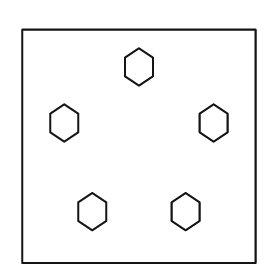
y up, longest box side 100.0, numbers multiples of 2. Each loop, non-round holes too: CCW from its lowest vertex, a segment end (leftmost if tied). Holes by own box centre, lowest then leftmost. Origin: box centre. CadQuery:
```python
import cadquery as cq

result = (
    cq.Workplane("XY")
    .moveTo(-50.0, -50.0)
    .lineTo(50.0, -50.0)
    .lineTo(50.0, 50.0)
    .lineTo(-50.0, 50.0)
    .close()
    .moveTo(-20.0, -36.0)
    .lineTo(-14.0, -32.0)
    .lineTo(-14.0, -24.0)
    .lineTo(-20.0, -20.0)
    .lineTo(-26.0, -24.0)
    .lineTo(-26.0, -32.0)
    .close()
    .moveTo(20.0, -36.0)
    .lineTo(26.0, -32.0)
    .lineTo(26.0, -24.0)
    .lineTo(20.0, -20.0)
    .lineTo(14.0, -24.0)
    .lineTo(14.0, -32.0)
    .close()
    .moveTo(-32.0, 2.0)
    .lineTo(-26.0, 6.0)
    .lineTo(-26.0, 14.0)
    .lineTo(-32.0, 18.0)
    .lineTo(-38.0, 14.0)
    .lineTo(-38.0, 6.0)
    .close()
    .moveTo(32.0, 2.0)
    .lineTo(38.0, 6.0)
    .lineTo(38.0, 14.0)
    .lineTo(32.0, 18.0)
    .lineTo(26.0, 14.0)
    .lineTo(26.0, 6.0)
    .close()
    .moveTo(0.0, 26.0)
    .lineTo(6.0, 30.0)
    .lineTo(6.0, 38.0)
    .lineTo(0.0, 42.0)
    .lineTo(-6.0, 38.0)
    .lineTo(-6.0, 30.0)
    .close()
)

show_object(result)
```